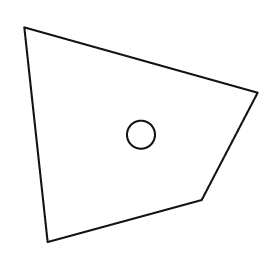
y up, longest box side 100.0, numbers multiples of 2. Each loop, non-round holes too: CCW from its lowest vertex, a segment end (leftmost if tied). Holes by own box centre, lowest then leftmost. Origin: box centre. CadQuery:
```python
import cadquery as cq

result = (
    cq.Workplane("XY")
    .moveTo(-40.0, -46.0)
    .lineTo(26.0, -28.0)
    .lineTo(50.0, 18.0)
    .lineTo(-50.0, 46.0)
    .close()
    .moveTo(0.0, 0.0)
    .circle(6.0)
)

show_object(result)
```